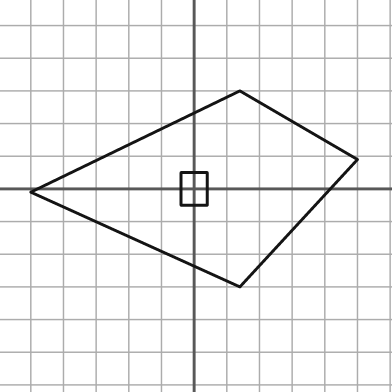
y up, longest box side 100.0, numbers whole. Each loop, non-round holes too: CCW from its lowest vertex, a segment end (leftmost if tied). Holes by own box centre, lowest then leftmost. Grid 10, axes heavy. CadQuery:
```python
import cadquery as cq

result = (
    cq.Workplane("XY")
    .moveTo(14.0, -30.0)
    .lineTo(50.0, 9.0)
    .lineTo(14.0, 30.0)
    .lineTo(-50.0, -1.0)
    .close()
    .moveTo(-4.0, -5.0)
    .lineTo(4.0, -5.0)
    .lineTo(4.0, 5.0)
    .lineTo(-4.0, 5.0)
    .close()
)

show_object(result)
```